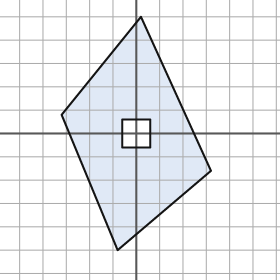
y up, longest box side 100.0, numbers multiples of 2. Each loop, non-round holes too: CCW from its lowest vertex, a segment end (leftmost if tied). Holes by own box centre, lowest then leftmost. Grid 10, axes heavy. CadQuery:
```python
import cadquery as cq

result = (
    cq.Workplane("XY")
    .moveTo(-8.0, -50.0)
    .lineTo(32.0, -16.0)
    .lineTo(2.0, 50.0)
    .lineTo(-32.0, 8.0)
    .close()
    .moveTo(-6.0, -6.0)
    .lineTo(6.0, -6.0)
    .lineTo(6.0, 6.0)
    .lineTo(-6.0, 6.0)
    .close()
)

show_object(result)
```